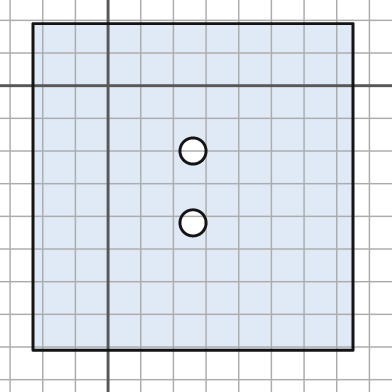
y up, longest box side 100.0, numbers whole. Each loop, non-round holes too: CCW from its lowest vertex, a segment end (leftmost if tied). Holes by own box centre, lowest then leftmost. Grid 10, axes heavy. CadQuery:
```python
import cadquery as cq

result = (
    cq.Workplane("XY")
    .moveTo(-23.0, -81.0)
    .lineTo(75.0, -81.0)
    .lineTo(75.0, 19.0)
    .lineTo(-23.0, 19.0)
    .close()
    .moveTo(26.0, -42.0)
    .circle(4.0)
    .moveTo(26.0, -20.0)
    .circle(4.0)
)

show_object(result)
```